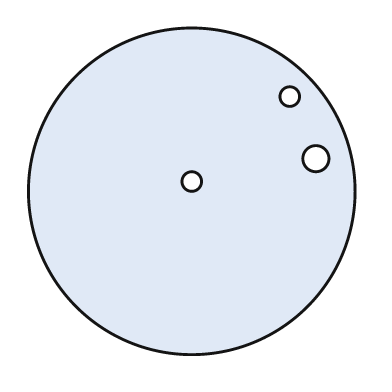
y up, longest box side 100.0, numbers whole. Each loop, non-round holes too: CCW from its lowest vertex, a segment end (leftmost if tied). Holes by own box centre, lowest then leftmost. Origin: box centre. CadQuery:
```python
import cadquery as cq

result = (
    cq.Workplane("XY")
    .moveTo(0.0, 0.0)
    .circle(50.0)
    .moveTo(0.0, 3.0)
    .circle(3.0)
    .moveTo(38.0, 10.0)
    .circle(4.0)
    .moveTo(30.0, 29.0)
    .circle(3.0)
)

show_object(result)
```